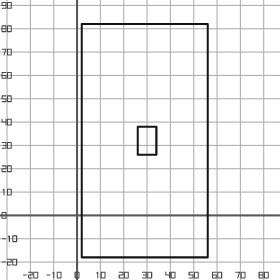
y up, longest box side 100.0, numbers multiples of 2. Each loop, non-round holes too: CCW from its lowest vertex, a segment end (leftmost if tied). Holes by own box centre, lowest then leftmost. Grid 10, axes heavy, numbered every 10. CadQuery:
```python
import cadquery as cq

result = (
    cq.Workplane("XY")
    .moveTo(2.0, -18.0)
    .lineTo(56.0, -18.0)
    .lineTo(56.0, 82.0)
    .lineTo(2.0, 82.0)
    .close()
    .moveTo(26.0, 26.0)
    .lineTo(34.0, 26.0)
    .lineTo(34.0, 38.0)
    .lineTo(26.0, 38.0)
    .close()
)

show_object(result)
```